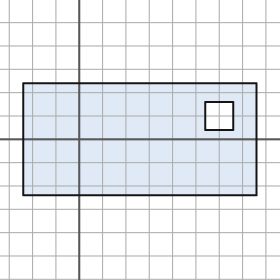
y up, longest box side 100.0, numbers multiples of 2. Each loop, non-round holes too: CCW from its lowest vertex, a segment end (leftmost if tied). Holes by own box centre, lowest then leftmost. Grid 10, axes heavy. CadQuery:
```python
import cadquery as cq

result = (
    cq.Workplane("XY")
    .moveTo(-24.0, -24.0)
    .lineTo(76.0, -24.0)
    .lineTo(76.0, 24.0)
    .lineTo(-24.0, 24.0)
    .close()
    .moveTo(54.0, 4.0)
    .lineTo(66.0, 4.0)
    .lineTo(66.0, 16.0)
    .lineTo(54.0, 16.0)
    .close()
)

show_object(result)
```